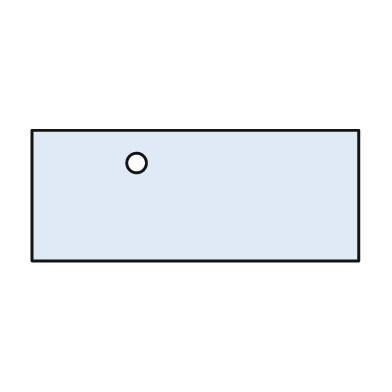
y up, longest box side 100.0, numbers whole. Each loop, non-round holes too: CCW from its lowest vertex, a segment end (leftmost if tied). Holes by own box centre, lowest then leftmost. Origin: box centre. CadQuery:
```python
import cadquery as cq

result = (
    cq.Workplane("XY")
    .moveTo(-50.0, -20.0)
    .lineTo(50.0, -20.0)
    .lineTo(50.0, 20.0)
    .lineTo(-50.0, 20.0)
    .close()
    .moveTo(-18.0, 10.0)
    .circle(3.0)
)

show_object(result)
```